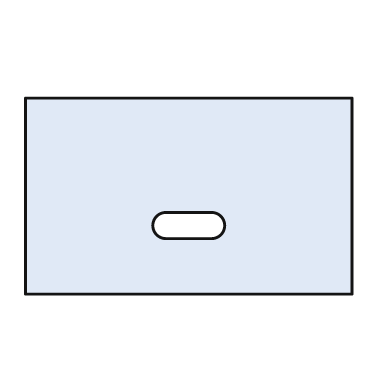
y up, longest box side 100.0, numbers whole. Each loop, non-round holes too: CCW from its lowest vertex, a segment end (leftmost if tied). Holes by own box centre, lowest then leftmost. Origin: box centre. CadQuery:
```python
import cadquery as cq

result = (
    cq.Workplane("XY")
    .moveTo(-50.0, -30.0)
    .lineTo(50.0, -30.0)
    .lineTo(50.0, 30.0)
    .lineTo(-50.0, 30.0)
    .close()
    .moveTo(-7.0, -13.0)
    .lineTo(7.0, -13.0)
    .threePointArc((11.0, -9.0), (7.0, -5.0))
    .lineTo(-7.0, -5.0)
    .threePointArc((-11.0, -9.0), (-7.0, -13.0))
    .close()
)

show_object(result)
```